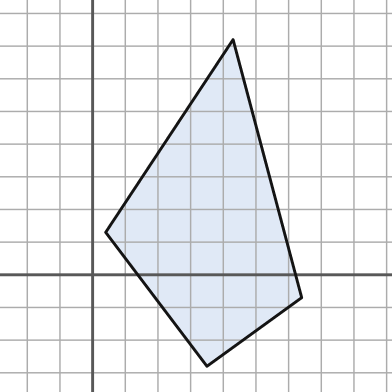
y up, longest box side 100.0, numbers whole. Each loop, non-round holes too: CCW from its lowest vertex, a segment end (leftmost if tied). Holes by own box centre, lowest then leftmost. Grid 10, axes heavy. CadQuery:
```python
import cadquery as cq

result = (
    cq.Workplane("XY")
    .moveTo(35.0, -28.0)
    .lineTo(64.0, -7.0)
    .lineTo(43.0, 72.0)
    .lineTo(4.0, 13.0)
    .close()
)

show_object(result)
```